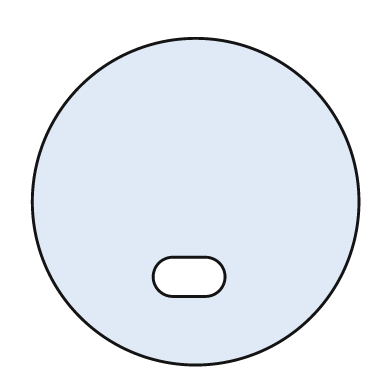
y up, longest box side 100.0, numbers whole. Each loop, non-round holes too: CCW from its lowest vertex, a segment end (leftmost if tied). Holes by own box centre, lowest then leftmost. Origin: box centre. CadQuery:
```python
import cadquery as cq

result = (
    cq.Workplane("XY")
    .moveTo(0.0, 0.0)
    .circle(50.0)
    .moveTo(-7.0, -29.0)
    .lineTo(3.0, -29.0)
    .threePointArc((9.0, -23.0), (3.0, -17.0))
    .lineTo(-7.0, -17.0)
    .threePointArc((-13.0, -23.0), (-7.0, -29.0))
    .close()
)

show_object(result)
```